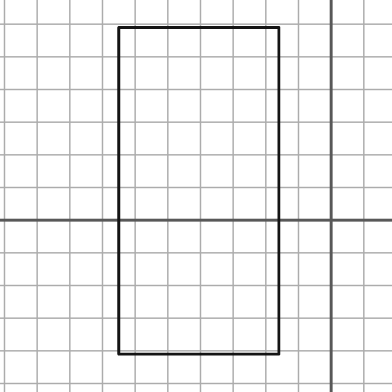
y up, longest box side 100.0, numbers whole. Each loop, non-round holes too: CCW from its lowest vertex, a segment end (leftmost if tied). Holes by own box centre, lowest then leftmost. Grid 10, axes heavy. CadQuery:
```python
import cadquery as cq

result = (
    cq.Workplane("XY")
    .moveTo(-65.0, -41.0)
    .lineTo(-16.0, -41.0)
    .lineTo(-16.0, 59.0)
    .lineTo(-65.0, 59.0)
    .close()
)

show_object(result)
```